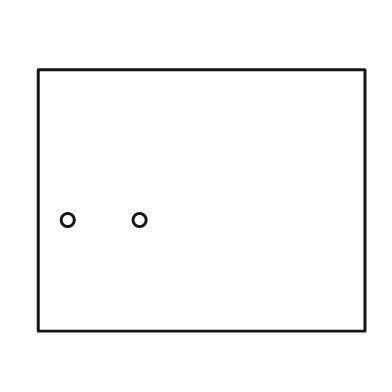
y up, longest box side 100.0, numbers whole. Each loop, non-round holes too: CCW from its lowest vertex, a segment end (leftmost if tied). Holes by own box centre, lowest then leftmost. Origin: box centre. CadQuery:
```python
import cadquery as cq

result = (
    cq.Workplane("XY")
    .moveTo(-50.0, -40.0)
    .lineTo(50.0, -40.0)
    .lineTo(50.0, 40.0)
    .lineTo(-50.0, 40.0)
    .close()
    .moveTo(-41.0, -6.0)
    .circle(2.0)
    .moveTo(-19.0, -6.0)
    .circle(2.0)
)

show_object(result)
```